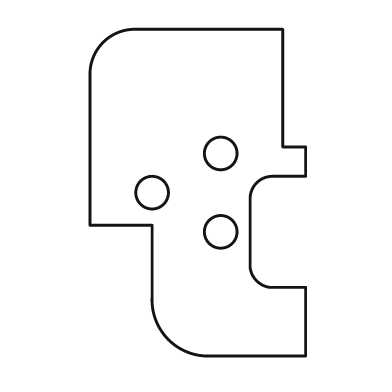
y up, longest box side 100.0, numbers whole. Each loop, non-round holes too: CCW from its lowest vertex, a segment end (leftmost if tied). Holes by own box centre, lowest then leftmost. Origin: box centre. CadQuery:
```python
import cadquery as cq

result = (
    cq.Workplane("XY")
    .moveTo(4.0, -50.0)
    .lineTo(33.0, -50.0)
    .lineTo(33.0, -29.0)
    .lineTo(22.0, -29.0)
    .threePointArc((18.0, -27.0), (16.0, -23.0))
    .lineTo(16.0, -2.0)
    .threePointArc((18.0, 3.0), (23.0, 5.0))
    .lineTo(33.0, 5.0)
    .lineTo(33.0, 14.0)
    .lineTo(26.0, 14.0)
    .lineTo(26.0, 50.0)
    .lineTo(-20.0, 50.0)
    .threePointArc((-29.0, 46.0), (-33.0, 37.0))
    .lineTo(-33.0, -10.0)
    .lineTo(-14.0, -10.0)
    .lineTo(-14.0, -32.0)
    .threePointArc((-9.0, -45.0), (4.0, -50.0))
    .close()
    .moveTo(7.0, -12.0)
    .circle(5.0)
    .moveTo(-14.0, 0.0)
    .circle(5.0)
    .moveTo(7.0, 12.0)
    .circle(5.0)
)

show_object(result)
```